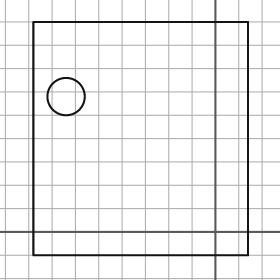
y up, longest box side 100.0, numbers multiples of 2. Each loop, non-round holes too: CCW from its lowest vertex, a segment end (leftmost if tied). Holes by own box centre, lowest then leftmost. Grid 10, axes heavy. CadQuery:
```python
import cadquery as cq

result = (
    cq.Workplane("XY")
    .moveTo(-78.0, -10.0)
    .lineTo(14.0, -10.0)
    .lineTo(14.0, 90.0)
    .lineTo(-78.0, 90.0)
    .close()
    .moveTo(-64.0, 58.0)
    .circle(8.0)
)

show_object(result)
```